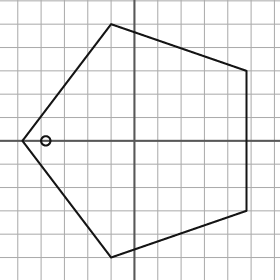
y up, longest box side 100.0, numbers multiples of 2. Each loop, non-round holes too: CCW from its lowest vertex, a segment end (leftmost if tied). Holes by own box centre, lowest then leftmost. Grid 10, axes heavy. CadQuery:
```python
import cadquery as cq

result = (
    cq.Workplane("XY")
    .moveTo(-10.0, -50.0)
    .lineTo(48.0, -30.0)
    .lineTo(48.0, 30.0)
    .lineTo(-10.0, 50.0)
    .lineTo(-48.0, 0.0)
    .close()
    .moveTo(-38.0, 0.0)
    .circle(2.0)
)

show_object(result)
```